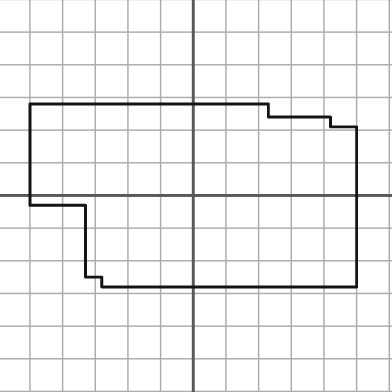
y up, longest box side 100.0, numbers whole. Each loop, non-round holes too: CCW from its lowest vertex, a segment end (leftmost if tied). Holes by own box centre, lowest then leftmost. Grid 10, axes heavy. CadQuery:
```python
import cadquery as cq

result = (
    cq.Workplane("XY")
    .moveTo(-28.0, -28.0)
    .lineTo(50.0, -28.0)
    .lineTo(50.0, 21.0)
    .lineTo(42.0, 21.0)
    .lineTo(42.0, 24.0)
    .lineTo(23.0, 24.0)
    .lineTo(23.0, 28.0)
    .lineTo(-50.0, 28.0)
    .lineTo(-50.0, -3.0)
    .lineTo(-33.0, -3.0)
    .lineTo(-33.0, -25.0)
    .lineTo(-28.0, -25.0)
    .close()
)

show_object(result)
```